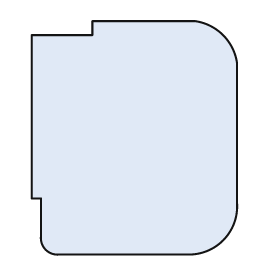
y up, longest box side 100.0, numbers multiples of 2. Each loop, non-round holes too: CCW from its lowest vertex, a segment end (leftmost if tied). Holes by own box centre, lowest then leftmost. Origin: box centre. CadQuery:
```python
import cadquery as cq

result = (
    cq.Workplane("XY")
    .moveTo(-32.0, -50.0)
    .lineTo(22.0, -50.0)
    .threePointArc((38.0, -44.0), (44.0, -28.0))
    .lineTo(44.0, 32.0)
    .threePointArc((38.0, 44.0), (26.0, 50.0))
    .lineTo(-18.0, 50.0)
    .lineTo(-18.0, 44.0)
    .lineTo(-44.0, 44.0)
    .lineTo(-44.0, -26.0)
    .lineTo(-40.0, -26.0)
    .lineTo(-40.0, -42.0)
    .threePointArc((-38.0, -48.0), (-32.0, -50.0))
    .close()
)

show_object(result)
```